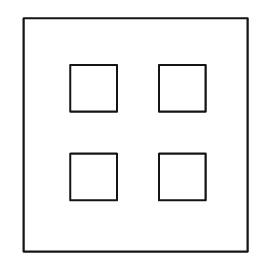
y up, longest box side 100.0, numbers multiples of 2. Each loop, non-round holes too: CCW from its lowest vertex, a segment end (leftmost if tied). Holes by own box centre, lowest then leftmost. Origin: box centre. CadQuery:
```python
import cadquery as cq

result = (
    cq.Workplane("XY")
    .moveTo(-48.0, -50.0)
    .lineTo(48.0, -50.0)
    .lineTo(48.0, 50.0)
    .lineTo(-48.0, 50.0)
    .close()
    .moveTo(-28.0, -28.0)
    .lineTo(-8.0, -28.0)
    .lineTo(-8.0, -8.0)
    .lineTo(-28.0, -8.0)
    .close()
    .moveTo(10.0, -28.0)
    .lineTo(30.0, -28.0)
    .lineTo(30.0, -8.0)
    .lineTo(10.0, -8.0)
    .close()
    .moveTo(-28.0, 10.0)
    .lineTo(-8.0, 10.0)
    .lineTo(-8.0, 30.0)
    .lineTo(-28.0, 30.0)
    .close()
    .moveTo(10.0, 10.0)
    .lineTo(30.0, 10.0)
    .lineTo(30.0, 30.0)
    .lineTo(10.0, 30.0)
    .close()
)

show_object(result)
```